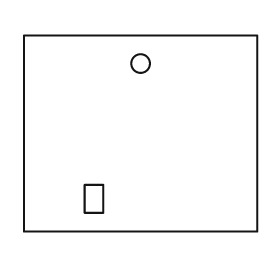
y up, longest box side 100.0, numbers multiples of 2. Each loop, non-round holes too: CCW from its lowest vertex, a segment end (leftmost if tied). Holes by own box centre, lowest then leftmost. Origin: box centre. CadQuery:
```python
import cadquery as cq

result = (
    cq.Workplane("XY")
    .moveTo(-50.0, -42.0)
    .lineTo(50.0, -42.0)
    .lineTo(50.0, 42.0)
    .lineTo(-50.0, 42.0)
    .close()
    .moveTo(-24.0, -34.0)
    .lineTo(-16.0, -34.0)
    .lineTo(-16.0, -22.0)
    .lineTo(-24.0, -22.0)
    .close()
    .moveTo(0.0, 30.0)
    .circle(4.0)
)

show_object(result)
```